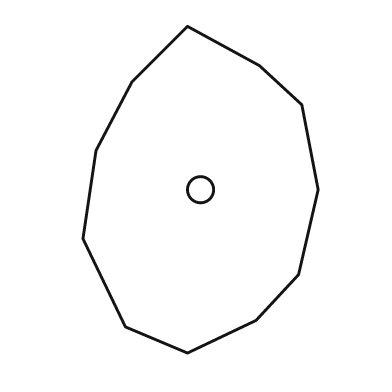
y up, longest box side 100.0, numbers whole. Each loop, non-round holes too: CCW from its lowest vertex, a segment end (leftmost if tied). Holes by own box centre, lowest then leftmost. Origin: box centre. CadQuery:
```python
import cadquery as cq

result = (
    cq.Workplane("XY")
    .moveTo(-4.0, -50.0)
    .lineTo(17.0, -40.0)
    .lineTo(30.0, -26.0)
    .lineTo(36.0, 0.0)
    .lineTo(31.0, 26.0)
    .lineTo(18.0, 38.0)
    .lineTo(-4.0, 50.0)
    .lineTo(-21.0, 33.0)
    .lineTo(-32.0, 12.0)
    .lineTo(-36.0, -15.0)
    .lineTo(-23.0, -42.0)
    .close()
    .moveTo(0.0, 0.0)
    .circle(4.0)
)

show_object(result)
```